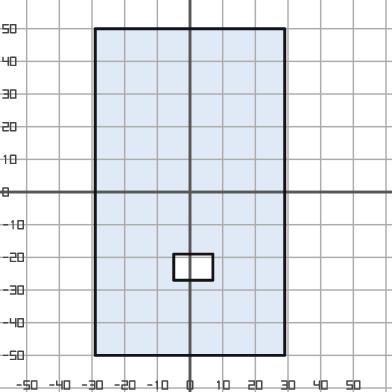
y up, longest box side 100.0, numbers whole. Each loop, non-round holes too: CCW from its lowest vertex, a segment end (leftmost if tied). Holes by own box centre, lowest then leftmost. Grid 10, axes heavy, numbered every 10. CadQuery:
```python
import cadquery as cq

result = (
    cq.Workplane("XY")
    .moveTo(-29.0, -50.0)
    .lineTo(29.0, -50.0)
    .lineTo(29.0, 50.0)
    .lineTo(-29.0, 50.0)
    .close()
    .moveTo(-5.0, -27.0)
    .lineTo(7.0, -27.0)
    .lineTo(7.0, -19.0)
    .lineTo(-5.0, -19.0)
    .close()
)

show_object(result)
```